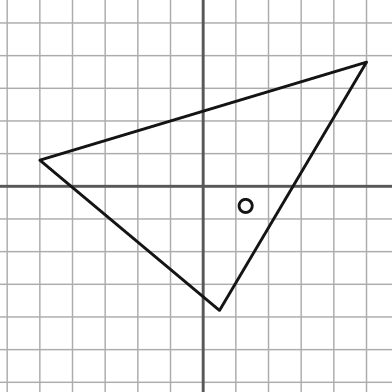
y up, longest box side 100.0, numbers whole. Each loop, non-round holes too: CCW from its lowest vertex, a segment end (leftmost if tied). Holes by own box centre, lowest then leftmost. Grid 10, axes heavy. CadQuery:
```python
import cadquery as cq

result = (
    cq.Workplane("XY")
    .moveTo(5.0, -38.0)
    .lineTo(50.0, 38.0)
    .lineTo(-50.0, 8.0)
    .close()
    .moveTo(13.0, -6.0)
    .circle(2.0)
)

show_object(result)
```